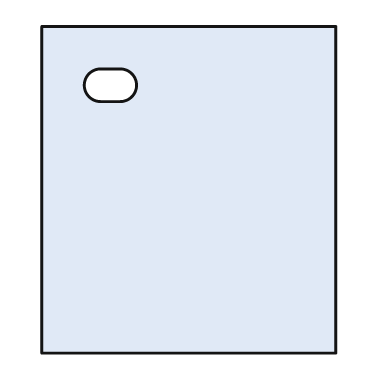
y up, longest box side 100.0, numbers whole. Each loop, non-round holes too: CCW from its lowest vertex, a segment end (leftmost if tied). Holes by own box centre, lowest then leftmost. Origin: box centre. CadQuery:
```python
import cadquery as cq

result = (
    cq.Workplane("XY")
    .moveTo(-45.0, -50.0)
    .lineTo(45.0, -50.0)
    .lineTo(45.0, 50.0)
    .lineTo(-45.0, 50.0)
    .close()
    .moveTo(-27.0, 27.0)
    .lineTo(-21.0, 27.0)
    .threePointArc((-16.0, 32.0), (-21.0, 37.0))
    .lineTo(-27.0, 37.0)
    .threePointArc((-32.0, 32.0), (-27.0, 27.0))
    .close()
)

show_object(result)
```